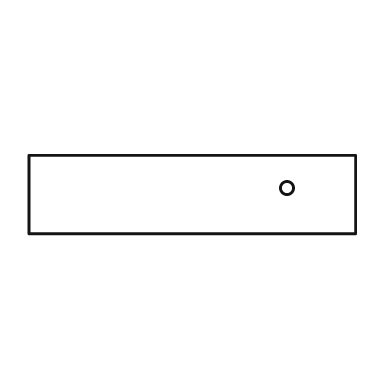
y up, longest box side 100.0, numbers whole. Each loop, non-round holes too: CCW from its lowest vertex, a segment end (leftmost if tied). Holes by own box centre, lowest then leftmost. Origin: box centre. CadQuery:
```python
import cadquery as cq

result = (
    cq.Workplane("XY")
    .moveTo(-50.0, -12.0)
    .lineTo(50.0, -12.0)
    .lineTo(50.0, 12.0)
    .lineTo(-50.0, 12.0)
    .close()
    .moveTo(29.0, 2.0)
    .circle(2.0)
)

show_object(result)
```